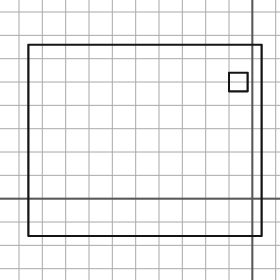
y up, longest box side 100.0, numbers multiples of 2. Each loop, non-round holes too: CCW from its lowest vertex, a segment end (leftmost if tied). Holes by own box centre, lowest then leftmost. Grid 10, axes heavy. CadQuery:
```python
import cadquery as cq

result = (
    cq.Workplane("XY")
    .moveTo(-96.0, -16.0)
    .lineTo(4.0, -16.0)
    .lineTo(4.0, 66.0)
    .lineTo(-96.0, 66.0)
    .close()
    .moveTo(-10.0, 46.0)
    .lineTo(-2.0, 46.0)
    .lineTo(-2.0, 54.0)
    .lineTo(-10.0, 54.0)
    .close()
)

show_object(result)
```